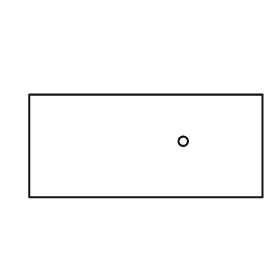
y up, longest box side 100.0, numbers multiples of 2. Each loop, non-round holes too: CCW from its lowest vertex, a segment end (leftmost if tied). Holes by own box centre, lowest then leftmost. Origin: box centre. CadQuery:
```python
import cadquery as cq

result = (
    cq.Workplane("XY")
    .moveTo(-50.0, -22.0)
    .lineTo(50.0, -22.0)
    .lineTo(50.0, 22.0)
    .lineTo(-50.0, 22.0)
    .close()
    .moveTo(16.0, 2.0)
    .circle(2.0)
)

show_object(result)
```